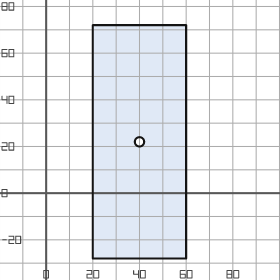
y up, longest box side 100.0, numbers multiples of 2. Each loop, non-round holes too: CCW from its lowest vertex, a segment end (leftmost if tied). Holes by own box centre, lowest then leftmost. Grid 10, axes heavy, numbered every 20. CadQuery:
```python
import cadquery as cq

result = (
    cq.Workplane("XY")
    .moveTo(20.0, -28.0)
    .lineTo(60.0, -28.0)
    .lineTo(60.0, 72.0)
    .lineTo(20.0, 72.0)
    .close()
    .moveTo(40.0, 22.0)
    .circle(2.0)
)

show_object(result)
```